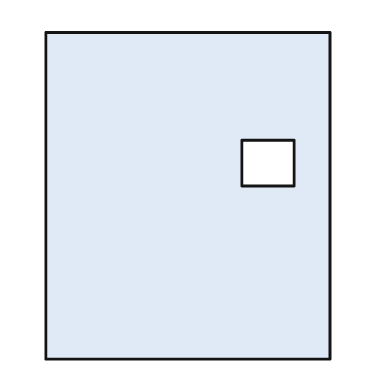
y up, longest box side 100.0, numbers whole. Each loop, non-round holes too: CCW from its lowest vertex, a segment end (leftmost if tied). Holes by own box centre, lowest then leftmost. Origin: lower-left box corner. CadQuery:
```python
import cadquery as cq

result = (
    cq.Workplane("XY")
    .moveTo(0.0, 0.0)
    .lineTo(87.0, 0.0)
    .lineTo(87.0, 100.0)
    .lineTo(0.0, 100.0)
    .close()
    .moveTo(60.0, 53.0)
    .lineTo(76.0, 53.0)
    .lineTo(76.0, 67.0)
    .lineTo(60.0, 67.0)
    .close()
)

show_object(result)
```